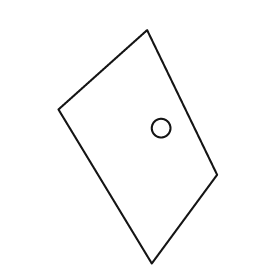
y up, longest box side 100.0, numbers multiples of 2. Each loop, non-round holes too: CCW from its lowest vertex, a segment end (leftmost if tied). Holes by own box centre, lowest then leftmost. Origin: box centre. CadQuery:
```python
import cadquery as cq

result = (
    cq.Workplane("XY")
    .moveTo(6.0, -50.0)
    .lineTo(34.0, -12.0)
    .lineTo(4.0, 50.0)
    .lineTo(-34.0, 16.0)
    .close()
    .moveTo(10.0, 8.0)
    .circle(4.0)
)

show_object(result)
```